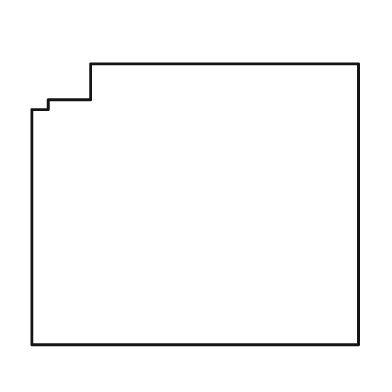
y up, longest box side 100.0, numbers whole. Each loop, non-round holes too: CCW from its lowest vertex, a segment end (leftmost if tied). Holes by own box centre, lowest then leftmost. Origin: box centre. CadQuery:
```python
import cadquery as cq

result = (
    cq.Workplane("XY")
    .moveTo(-50.0, -43.0)
    .lineTo(50.0, -43.0)
    .lineTo(50.0, 43.0)
    .lineTo(-32.0, 43.0)
    .lineTo(-32.0, 32.0)
    .lineTo(-45.0, 32.0)
    .lineTo(-45.0, 29.0)
    .lineTo(-50.0, 29.0)
    .close()
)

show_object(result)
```